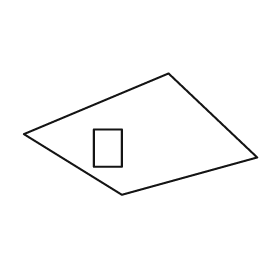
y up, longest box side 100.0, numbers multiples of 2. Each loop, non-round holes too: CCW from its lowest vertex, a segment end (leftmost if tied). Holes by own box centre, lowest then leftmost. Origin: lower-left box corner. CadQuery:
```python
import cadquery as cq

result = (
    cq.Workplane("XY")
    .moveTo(42.0, 0.0)
    .lineTo(100.0, 16.0)
    .lineTo(62.0, 52.0)
    .lineTo(0.0, 26.0)
    .close()
    .moveTo(30.0, 12.0)
    .lineTo(42.0, 12.0)
    .lineTo(42.0, 28.0)
    .lineTo(30.0, 28.0)
    .close()
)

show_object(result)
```